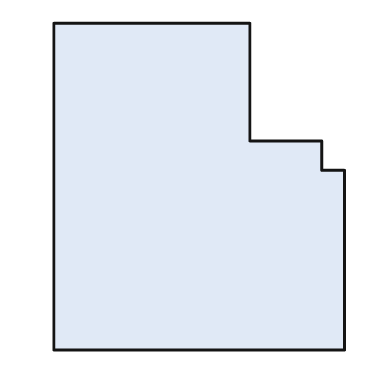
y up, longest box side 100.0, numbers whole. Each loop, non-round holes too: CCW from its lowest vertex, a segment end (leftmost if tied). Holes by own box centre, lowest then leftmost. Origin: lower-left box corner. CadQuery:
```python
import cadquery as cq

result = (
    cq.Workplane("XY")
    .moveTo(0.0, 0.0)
    .lineTo(89.0, 0.0)
    .lineTo(89.0, 55.0)
    .lineTo(82.0, 55.0)
    .lineTo(82.0, 64.0)
    .lineTo(60.0, 64.0)
    .lineTo(60.0, 100.0)
    .lineTo(0.0, 100.0)
    .close()
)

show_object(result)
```